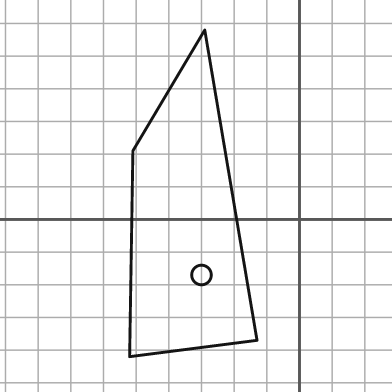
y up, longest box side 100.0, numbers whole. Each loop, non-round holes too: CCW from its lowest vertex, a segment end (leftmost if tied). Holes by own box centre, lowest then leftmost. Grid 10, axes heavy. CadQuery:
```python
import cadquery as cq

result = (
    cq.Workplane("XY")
    .moveTo(-52.0, -42.0)
    .lineTo(-13.0, -37.0)
    .lineTo(-29.0, 58.0)
    .lineTo(-51.0, 21.0)
    .close()
    .moveTo(-30.0, -17.0)
    .circle(3.0)
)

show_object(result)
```